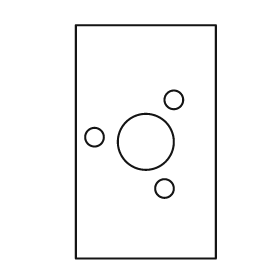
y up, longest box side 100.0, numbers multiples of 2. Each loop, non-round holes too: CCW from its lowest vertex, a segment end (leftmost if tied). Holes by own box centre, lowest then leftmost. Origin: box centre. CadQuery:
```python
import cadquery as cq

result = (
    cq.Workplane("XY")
    .moveTo(-30.0, -50.0)
    .lineTo(30.0, -50.0)
    .lineTo(30.0, 50.0)
    .lineTo(-30.0, 50.0)
    .close()
    .moveTo(8.0, -20.0)
    .circle(4.0)
    .moveTo(0.0, 0.0)
    .circle(12.0)
    .moveTo(-22.0, 2.0)
    .circle(4.0)
    .moveTo(12.0, 18.0)
    .circle(4.0)
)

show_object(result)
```